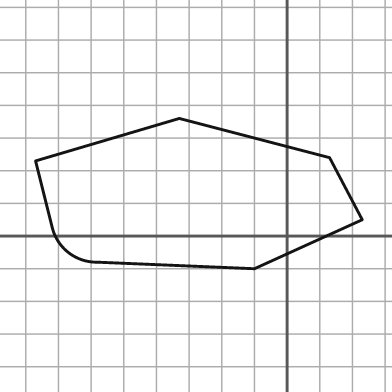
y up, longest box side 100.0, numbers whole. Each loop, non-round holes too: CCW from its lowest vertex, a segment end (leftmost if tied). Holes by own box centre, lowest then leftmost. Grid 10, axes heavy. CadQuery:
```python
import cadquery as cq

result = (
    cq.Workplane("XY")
    .moveTo(-10.0, -10.0)
    .lineTo(23.0, 5.0)
    .lineTo(13.0, 24.0)
    .lineTo(-33.0, 36.0)
    .lineTo(-77.0, 23.0)
    .lineTo(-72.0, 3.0)
    .threePointArc((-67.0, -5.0), (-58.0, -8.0))
    .close()
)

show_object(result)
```